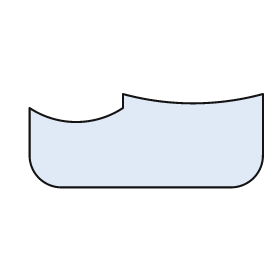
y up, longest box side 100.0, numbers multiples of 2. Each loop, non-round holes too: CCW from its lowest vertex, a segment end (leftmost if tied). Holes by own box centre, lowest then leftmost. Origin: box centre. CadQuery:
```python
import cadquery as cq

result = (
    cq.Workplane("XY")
    .moveTo(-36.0, -20.0)
    .lineTo(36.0, -20.0)
    .threePointArc((46.0, -16.0), (50.0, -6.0))
    .lineTo(50.0, 20.0)
    .threePointArc((20.0, 16.0), (-10.0, 20.0))
    .lineTo(-10.0, 14.0)
    .threePointArc((-30.0, 8.0), (-50.0, 14.0))
    .lineTo(-50.0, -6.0)
    .threePointArc((-46.0, -16.0), (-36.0, -20.0))
    .close()
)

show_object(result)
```